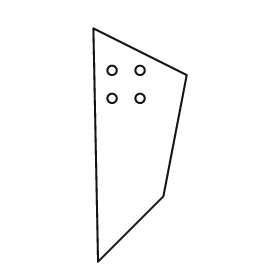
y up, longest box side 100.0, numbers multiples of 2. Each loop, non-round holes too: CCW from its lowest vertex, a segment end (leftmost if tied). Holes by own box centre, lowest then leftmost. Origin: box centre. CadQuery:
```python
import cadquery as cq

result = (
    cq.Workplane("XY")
    .moveTo(-18.0, -50.0)
    .lineTo(10.0, -22.0)
    .lineTo(20.0, 30.0)
    .lineTo(-20.0, 50.0)
    .close()
    .moveTo(-12.0, 20.0)
    .circle(2.0)
    .moveTo(0.0, 20.0)
    .circle(2.0)
    .moveTo(-12.0, 32.0)
    .circle(2.0)
    .moveTo(0.0, 32.0)
    .circle(2.0)
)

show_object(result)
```